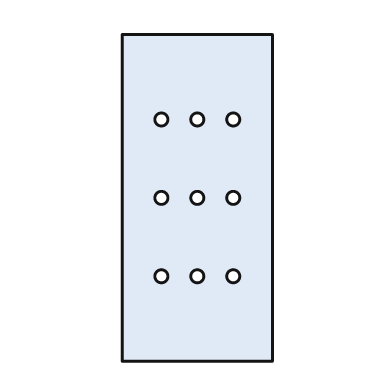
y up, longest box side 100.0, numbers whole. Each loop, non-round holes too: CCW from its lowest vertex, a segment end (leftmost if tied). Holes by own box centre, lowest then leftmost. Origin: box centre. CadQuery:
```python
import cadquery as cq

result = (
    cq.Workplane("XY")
    .moveTo(-23.0, -50.0)
    .lineTo(23.0, -50.0)
    .lineTo(23.0, 50.0)
    .lineTo(-23.0, 50.0)
    .close()
    .moveTo(-11.0, -24.0)
    .circle(2.0)
    .moveTo(0.0, -24.0)
    .circle(2.0)
    .moveTo(11.0, -24.0)
    .circle(2.0)
    .moveTo(-11.0, 0.0)
    .circle(2.0)
    .moveTo(0.0, 0.0)
    .circle(2.0)
    .moveTo(11.0, 0.0)
    .circle(2.0)
    .moveTo(-11.0, 24.0)
    .circle(2.0)
    .moveTo(0.0, 24.0)
    .circle(2.0)
    .moveTo(11.0, 24.0)
    .circle(2.0)
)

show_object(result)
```